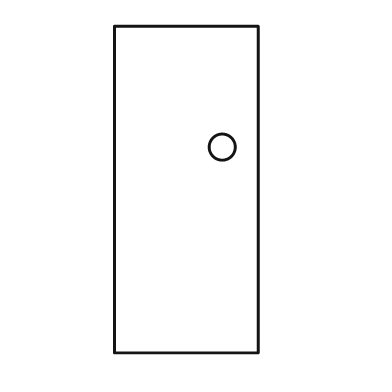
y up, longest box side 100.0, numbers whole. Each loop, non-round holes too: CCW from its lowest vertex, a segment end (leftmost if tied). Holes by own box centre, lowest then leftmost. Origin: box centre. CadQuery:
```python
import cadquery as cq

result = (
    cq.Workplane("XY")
    .moveTo(-22.0, -50.0)
    .lineTo(22.0, -50.0)
    .lineTo(22.0, 50.0)
    .lineTo(-22.0, 50.0)
    .close()
    .moveTo(11.0, 13.0)
    .circle(4.0)
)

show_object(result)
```